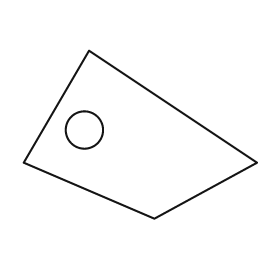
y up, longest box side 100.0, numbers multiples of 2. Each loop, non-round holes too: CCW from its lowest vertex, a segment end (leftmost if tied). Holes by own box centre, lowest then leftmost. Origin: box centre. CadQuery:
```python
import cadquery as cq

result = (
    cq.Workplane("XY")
    .moveTo(6.0, -36.0)
    .lineTo(50.0, -12.0)
    .lineTo(-22.0, 36.0)
    .lineTo(-50.0, -12.0)
    .close()
    .moveTo(-24.0, 2.0)
    .circle(8.0)
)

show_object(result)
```